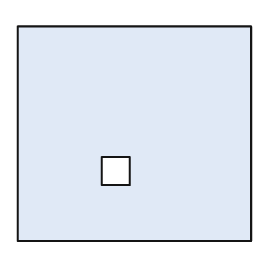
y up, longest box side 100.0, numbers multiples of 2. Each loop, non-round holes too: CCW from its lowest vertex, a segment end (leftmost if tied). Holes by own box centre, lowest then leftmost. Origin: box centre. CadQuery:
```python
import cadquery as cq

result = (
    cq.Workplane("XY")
    .moveTo(-50.0, -46.0)
    .lineTo(50.0, -46.0)
    .lineTo(50.0, 46.0)
    .lineTo(-50.0, 46.0)
    .close()
    .moveTo(-14.0, -22.0)
    .lineTo(-2.0, -22.0)
    .lineTo(-2.0, -10.0)
    .lineTo(-14.0, -10.0)
    .close()
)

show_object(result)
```